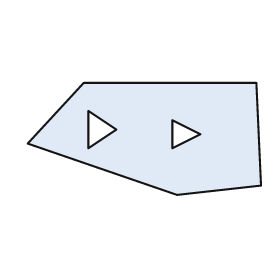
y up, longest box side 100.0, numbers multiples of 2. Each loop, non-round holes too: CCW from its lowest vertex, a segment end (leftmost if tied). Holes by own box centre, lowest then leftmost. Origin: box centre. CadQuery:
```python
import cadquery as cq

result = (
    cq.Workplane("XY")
    .moveTo(14.0, -24.0)
    .lineTo(50.0, -20.0)
    .lineTo(48.0, 24.0)
    .lineTo(-26.0, 24.0)
    .lineTo(-50.0, -2.0)
    .close()
    .moveTo(12.0, -4.0)
    .lineTo(24.0, 2.0)
    .lineTo(12.0, 8.0)
    .close()
    .moveTo(-24.0, -4.0)
    .lineTo(-12.0, 4.0)
    .lineTo(-24.0, 12.0)
    .close()
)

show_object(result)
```